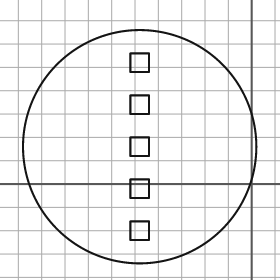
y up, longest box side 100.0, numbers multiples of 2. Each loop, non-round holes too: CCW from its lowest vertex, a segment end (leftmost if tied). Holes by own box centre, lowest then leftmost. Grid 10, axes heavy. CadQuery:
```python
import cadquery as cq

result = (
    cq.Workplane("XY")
    .moveTo(-48.0, 16.0)
    .circle(50.0)
    .moveTo(-52.0, -24.0)
    .lineTo(-44.0, -24.0)
    .lineTo(-44.0, -16.0)
    .lineTo(-52.0, -16.0)
    .close()
    .moveTo(-52.0, -6.0)
    .lineTo(-44.0, -6.0)
    .lineTo(-44.0, 2.0)
    .lineTo(-52.0, 2.0)
    .close()
    .moveTo(-52.0, 12.0)
    .lineTo(-44.0, 12.0)
    .lineTo(-44.0, 20.0)
    .lineTo(-52.0, 20.0)
    .close()
    .moveTo(-52.0, 30.0)
    .lineTo(-44.0, 30.0)
    .lineTo(-44.0, 38.0)
    .lineTo(-52.0, 38.0)
    .close()
    .moveTo(-52.0, 48.0)
    .lineTo(-44.0, 48.0)
    .lineTo(-44.0, 56.0)
    .lineTo(-52.0, 56.0)
    .close()
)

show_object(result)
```